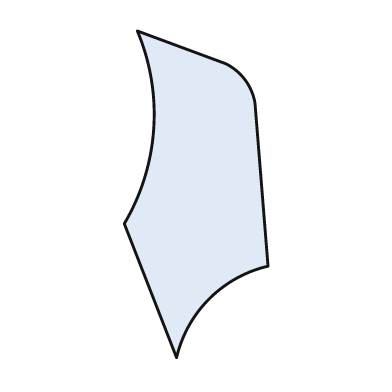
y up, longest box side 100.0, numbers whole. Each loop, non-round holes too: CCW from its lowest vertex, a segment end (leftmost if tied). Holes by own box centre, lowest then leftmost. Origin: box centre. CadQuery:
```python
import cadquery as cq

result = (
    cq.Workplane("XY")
    .moveTo(-6.0, -50.0)
    .threePointArc((4.0, -32.0), (22.0, -22.0))
    .lineTo(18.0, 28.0)
    .threePointArc((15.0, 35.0), (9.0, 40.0))
    .lineTo(-18.0, 50.0)
    .threePointArc((-13.0, 20.0), (-22.0, -9.0))
    .close()
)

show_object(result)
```